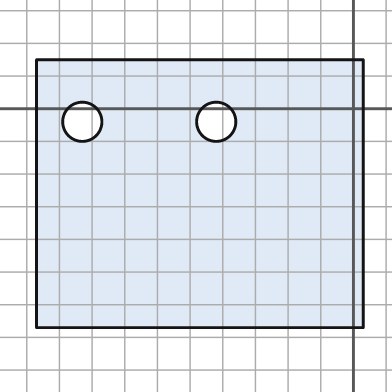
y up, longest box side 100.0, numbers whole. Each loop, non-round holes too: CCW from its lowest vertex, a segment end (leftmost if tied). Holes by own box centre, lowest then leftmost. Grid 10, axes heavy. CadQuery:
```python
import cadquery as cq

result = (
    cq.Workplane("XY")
    .moveTo(-97.0, -67.0)
    .lineTo(3.0, -67.0)
    .lineTo(3.0, 15.0)
    .lineTo(-97.0, 15.0)
    .close()
    .moveTo(-83.0, -4.0)
    .circle(6.0)
    .moveTo(-42.0, -4.0)
    .circle(6.0)
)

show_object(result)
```